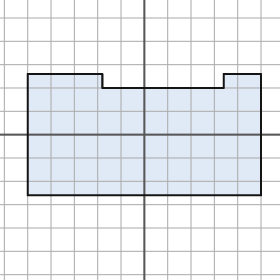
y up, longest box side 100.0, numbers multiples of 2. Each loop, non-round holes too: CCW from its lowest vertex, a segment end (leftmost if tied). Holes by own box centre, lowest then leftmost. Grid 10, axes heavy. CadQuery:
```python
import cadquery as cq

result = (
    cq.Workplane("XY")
    .moveTo(-50.0, -26.0)
    .lineTo(50.0, -26.0)
    .lineTo(50.0, 26.0)
    .lineTo(34.0, 26.0)
    .lineTo(34.0, 20.0)
    .lineTo(-18.0, 20.0)
    .lineTo(-18.0, 26.0)
    .lineTo(-50.0, 26.0)
    .close()
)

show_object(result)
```